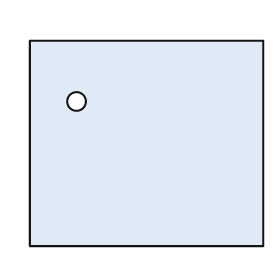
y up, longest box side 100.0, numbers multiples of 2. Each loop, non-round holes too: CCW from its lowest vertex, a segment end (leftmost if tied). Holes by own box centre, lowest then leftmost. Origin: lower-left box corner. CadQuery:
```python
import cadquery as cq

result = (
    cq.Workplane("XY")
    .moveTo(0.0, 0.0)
    .lineTo(100.0, 0.0)
    .lineTo(100.0, 88.0)
    .lineTo(0.0, 88.0)
    .close()
    .moveTo(20.0, 62.0)
    .circle(4.0)
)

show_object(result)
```